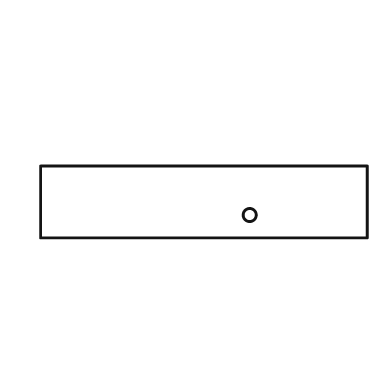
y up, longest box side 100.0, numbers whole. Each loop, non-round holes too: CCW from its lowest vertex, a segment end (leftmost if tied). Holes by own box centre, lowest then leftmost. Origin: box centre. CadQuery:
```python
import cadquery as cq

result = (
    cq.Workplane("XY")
    .moveTo(-50.0, -11.0)
    .lineTo(50.0, -11.0)
    .lineTo(50.0, 11.0)
    .lineTo(-50.0, 11.0)
    .close()
    .moveTo(14.0, -4.0)
    .circle(2.0)
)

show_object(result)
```